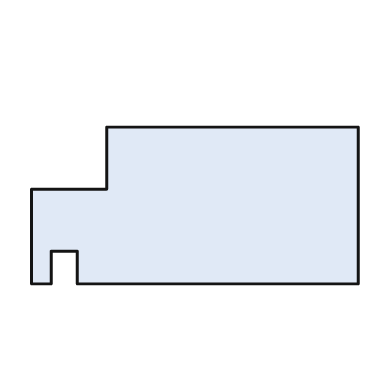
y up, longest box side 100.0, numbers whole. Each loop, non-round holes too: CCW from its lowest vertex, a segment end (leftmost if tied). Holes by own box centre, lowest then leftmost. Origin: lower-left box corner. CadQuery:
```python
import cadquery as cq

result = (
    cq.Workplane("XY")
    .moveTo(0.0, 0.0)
    .lineTo(6.0, 0.0)
    .lineTo(6.0, 10.0)
    .lineTo(14.0, 10.0)
    .lineTo(14.0, 0.0)
    .lineTo(100.0, 0.0)
    .lineTo(100.0, 48.0)
    .lineTo(23.0, 48.0)
    .lineTo(23.0, 29.0)
    .lineTo(0.0, 29.0)
    .close()
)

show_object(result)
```